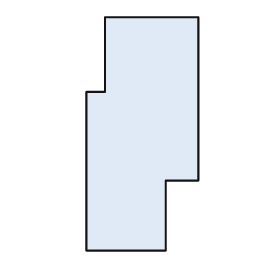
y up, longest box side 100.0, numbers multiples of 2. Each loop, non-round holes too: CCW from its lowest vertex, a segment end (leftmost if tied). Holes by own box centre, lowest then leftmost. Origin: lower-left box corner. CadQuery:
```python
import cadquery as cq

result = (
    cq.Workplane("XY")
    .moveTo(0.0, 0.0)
    .lineTo(34.0, 0.0)
    .lineTo(34.0, 30.0)
    .lineTo(48.0, 30.0)
    .lineTo(48.0, 100.0)
    .lineTo(8.0, 100.0)
    .lineTo(8.0, 68.0)
    .lineTo(0.0, 68.0)
    .close()
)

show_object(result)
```